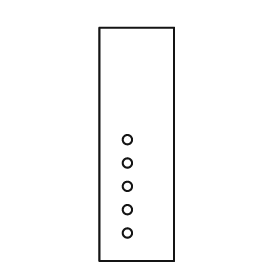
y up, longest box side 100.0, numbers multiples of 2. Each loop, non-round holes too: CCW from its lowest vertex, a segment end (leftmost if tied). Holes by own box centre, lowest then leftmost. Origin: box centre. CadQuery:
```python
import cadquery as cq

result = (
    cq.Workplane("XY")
    .moveTo(-16.0, -50.0)
    .lineTo(16.0, -50.0)
    .lineTo(16.0, 50.0)
    .lineTo(-16.0, 50.0)
    .close()
    .moveTo(-4.0, -38.0)
    .circle(2.0)
    .moveTo(-4.0, -28.0)
    .circle(2.0)
    .moveTo(-4.0, -18.0)
    .circle(2.0)
    .moveTo(-4.0, -8.0)
    .circle(2.0)
    .moveTo(-4.0, 2.0)
    .circle(2.0)
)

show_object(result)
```